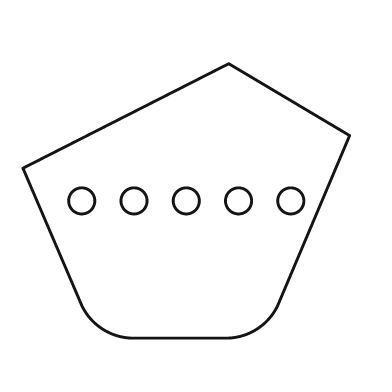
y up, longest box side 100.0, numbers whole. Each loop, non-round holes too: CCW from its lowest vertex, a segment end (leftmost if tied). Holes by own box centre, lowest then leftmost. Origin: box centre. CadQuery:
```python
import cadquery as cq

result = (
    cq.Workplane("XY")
    .moveTo(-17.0, -42.0)
    .lineTo(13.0, -42.0)
    .threePointArc((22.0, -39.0), (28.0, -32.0))
    .lineTo(50.0, 20.0)
    .lineTo(13.0, 42.0)
    .lineTo(-50.0, 10.0)
    .lineTo(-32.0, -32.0)
    .threePointArc((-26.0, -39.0), (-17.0, -42.0))
    .close()
    .moveTo(-32.0, 0.0)
    .circle(4.0)
    .moveTo(-16.0, 0.0)
    .circle(4.0)
    .moveTo(0.0, 0.0)
    .circle(4.0)
    .moveTo(16.0, 0.0)
    .circle(4.0)
    .moveTo(32.0, 0.0)
    .circle(4.0)
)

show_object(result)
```